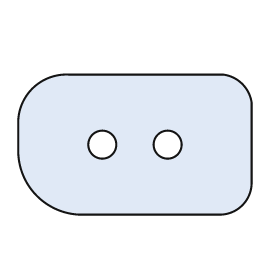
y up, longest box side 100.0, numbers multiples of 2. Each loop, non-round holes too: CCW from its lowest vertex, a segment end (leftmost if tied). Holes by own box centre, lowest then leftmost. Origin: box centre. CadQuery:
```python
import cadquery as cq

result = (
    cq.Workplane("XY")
    .moveTo(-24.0, -30.0)
    .lineTo(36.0, -30.0)
    .threePointArc((46.0, -26.0), (50.0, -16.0))
    .lineTo(50.0, 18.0)
    .threePointArc((46.0, 26.0), (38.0, 30.0))
    .lineTo(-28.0, 30.0)
    .threePointArc((-44.0, 24.0), (-50.0, 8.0))
    .lineTo(-50.0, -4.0)
    .threePointArc((-42.0, -22.0), (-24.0, -30.0))
    .close()
    .moveTo(-14.0, 0.0)
    .circle(6.0)
    .moveTo(14.0, 0.0)
    .circle(6.0)
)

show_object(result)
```